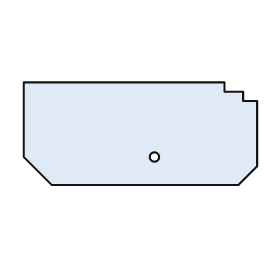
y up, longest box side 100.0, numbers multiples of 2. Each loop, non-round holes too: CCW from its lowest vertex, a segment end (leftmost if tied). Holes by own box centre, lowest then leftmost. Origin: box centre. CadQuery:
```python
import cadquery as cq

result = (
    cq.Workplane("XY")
    .moveTo(-38.0, -22.0)
    .lineTo(42.0, -22.0)
    .lineTo(50.0, -14.0)
    .lineTo(50.0, 14.0)
    .lineTo(44.0, 14.0)
    .lineTo(44.0, 18.0)
    .lineTo(36.0, 18.0)
    .lineTo(36.0, 22.0)
    .lineTo(-50.0, 22.0)
    .lineTo(-50.0, -10.0)
    .close()
    .moveTo(6.0, -10.0)
    .circle(2.0)
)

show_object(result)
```